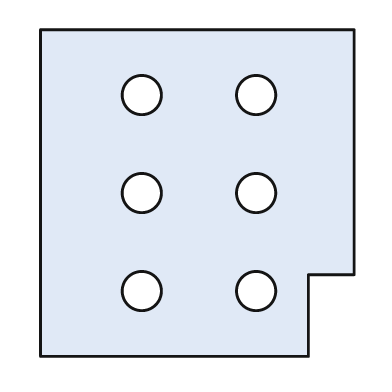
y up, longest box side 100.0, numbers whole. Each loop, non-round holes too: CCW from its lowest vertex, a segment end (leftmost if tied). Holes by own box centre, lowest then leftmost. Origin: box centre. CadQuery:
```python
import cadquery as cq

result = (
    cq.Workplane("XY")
    .moveTo(-48.0, -50.0)
    .lineTo(34.0, -50.0)
    .lineTo(34.0, -25.0)
    .lineTo(48.0, -25.0)
    .lineTo(48.0, 50.0)
    .lineTo(-48.0, 50.0)
    .close()
    .moveTo(-17.0, -30.0)
    .circle(6.0)
    .moveTo(18.0, -30.0)
    .circle(6.0)
    .moveTo(-17.0, 0.0)
    .circle(6.0)
    .moveTo(18.0, 0.0)
    .circle(6.0)
    .moveTo(-17.0, 30.0)
    .circle(6.0)
    .moveTo(18.0, 30.0)
    .circle(6.0)
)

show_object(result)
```